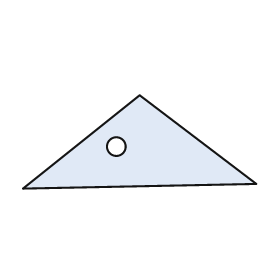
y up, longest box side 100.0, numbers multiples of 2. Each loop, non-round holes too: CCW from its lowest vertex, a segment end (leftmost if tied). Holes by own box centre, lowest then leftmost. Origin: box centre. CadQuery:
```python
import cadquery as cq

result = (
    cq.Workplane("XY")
    .moveTo(-50.0, -20.0)
    .lineTo(50.0, -18.0)
    .lineTo(0.0, 20.0)
    .close()
    .moveTo(-10.0, -2.0)
    .circle(4.0)
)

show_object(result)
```